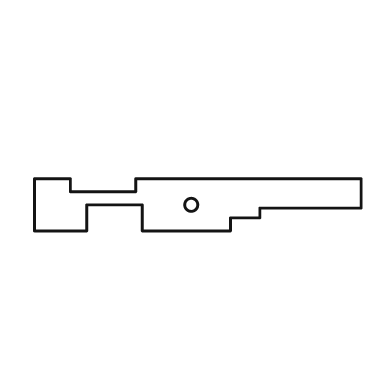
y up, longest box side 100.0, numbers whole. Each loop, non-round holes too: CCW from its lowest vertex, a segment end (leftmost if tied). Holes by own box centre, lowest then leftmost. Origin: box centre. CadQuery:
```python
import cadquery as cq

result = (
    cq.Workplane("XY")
    .moveTo(-50.0, -8.0)
    .lineTo(-34.0, -8.0)
    .lineTo(-34.0, 0.0)
    .lineTo(-17.0, 0.0)
    .lineTo(-17.0, -8.0)
    .lineTo(10.0, -8.0)
    .lineTo(10.0, -4.0)
    .lineTo(19.0, -4.0)
    .lineTo(19.0, -1.0)
    .lineTo(50.0, -1.0)
    .lineTo(50.0, 8.0)
    .lineTo(-19.0, 8.0)
    .lineTo(-19.0, 4.0)
    .lineTo(-39.0, 4.0)
    .lineTo(-39.0, 8.0)
    .lineTo(-50.0, 8.0)
    .close()
    .moveTo(-2.0, 0.0)
    .circle(2.0)
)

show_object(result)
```